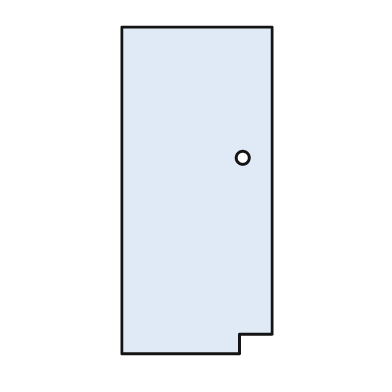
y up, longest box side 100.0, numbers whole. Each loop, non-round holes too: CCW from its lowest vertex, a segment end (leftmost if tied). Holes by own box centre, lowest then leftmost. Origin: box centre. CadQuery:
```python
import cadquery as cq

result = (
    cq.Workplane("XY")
    .moveTo(-23.0, -50.0)
    .lineTo(13.0, -50.0)
    .lineTo(13.0, -44.0)
    .lineTo(23.0, -44.0)
    .lineTo(23.0, 50.0)
    .lineTo(-23.0, 50.0)
    .close()
    .moveTo(14.0, 10.0)
    .circle(2.0)
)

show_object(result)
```